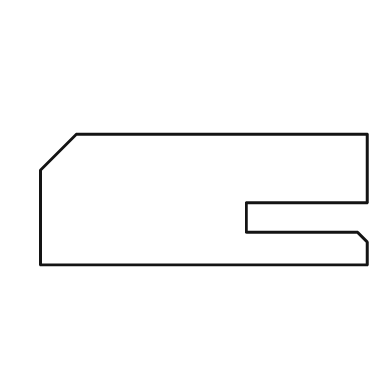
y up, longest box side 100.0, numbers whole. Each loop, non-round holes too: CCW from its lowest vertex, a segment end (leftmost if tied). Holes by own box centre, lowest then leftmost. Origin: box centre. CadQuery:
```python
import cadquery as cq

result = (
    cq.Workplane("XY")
    .moveTo(-50.0, -20.0)
    .lineTo(50.0, -20.0)
    .lineTo(50.0, -13.0)
    .lineTo(47.0, -10.0)
    .lineTo(13.0, -10.0)
    .lineTo(13.0, -1.0)
    .lineTo(50.0, -1.0)
    .lineTo(50.0, 20.0)
    .lineTo(-39.0, 20.0)
    .lineTo(-50.0, 9.0)
    .close()
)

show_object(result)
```